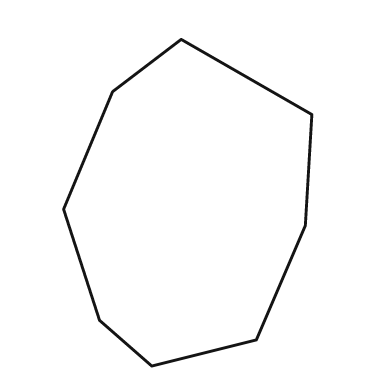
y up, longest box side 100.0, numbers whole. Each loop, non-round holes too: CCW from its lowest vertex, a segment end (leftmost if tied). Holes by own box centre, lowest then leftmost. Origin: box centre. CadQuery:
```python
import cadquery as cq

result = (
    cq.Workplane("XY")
    .moveTo(-11.0, -50.0)
    .lineTo(21.0, -42.0)
    .lineTo(36.0, -7.0)
    .lineTo(38.0, 27.0)
    .lineTo(-2.0, 50.0)
    .lineTo(-23.0, 34.0)
    .lineTo(-38.0, -2.0)
    .lineTo(-27.0, -36.0)
    .close()
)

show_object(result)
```